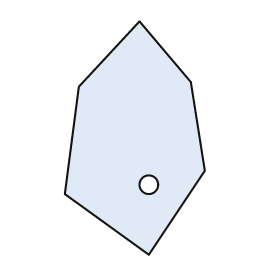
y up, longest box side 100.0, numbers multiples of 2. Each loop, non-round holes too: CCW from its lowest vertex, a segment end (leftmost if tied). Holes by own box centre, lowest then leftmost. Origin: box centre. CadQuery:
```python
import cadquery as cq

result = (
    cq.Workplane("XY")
    .moveTo(6.0, -50.0)
    .lineTo(30.0, -14.0)
    .lineTo(24.0, 24.0)
    .lineTo(2.0, 50.0)
    .lineTo(-24.0, 22.0)
    .lineTo(-30.0, -24.0)
    .close()
    .moveTo(6.0, -20.0)
    .circle(4.0)
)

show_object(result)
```